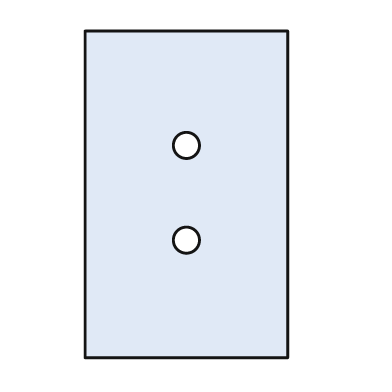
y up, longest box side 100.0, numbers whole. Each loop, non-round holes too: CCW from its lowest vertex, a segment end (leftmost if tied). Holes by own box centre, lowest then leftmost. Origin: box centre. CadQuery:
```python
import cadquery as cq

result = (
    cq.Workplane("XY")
    .moveTo(-31.0, -50.0)
    .lineTo(31.0, -50.0)
    .lineTo(31.0, 50.0)
    .lineTo(-31.0, 50.0)
    .close()
    .moveTo(0.0, -14.0)
    .circle(4.0)
    .moveTo(0.0, 15.0)
    .circle(4.0)
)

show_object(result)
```